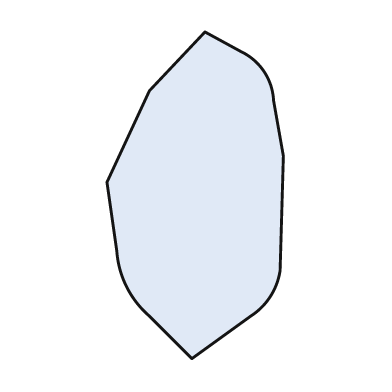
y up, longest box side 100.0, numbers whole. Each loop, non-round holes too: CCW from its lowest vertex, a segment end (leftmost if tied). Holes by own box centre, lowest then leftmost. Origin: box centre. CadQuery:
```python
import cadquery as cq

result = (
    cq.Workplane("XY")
    .moveTo(-1.0, -50.0)
    .lineTo(17.0, -37.0)
    .threePointArc((23.0, -31.0), (26.0, -23.0))
    .lineTo(27.0, 12.0)
    .lineTo(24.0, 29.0)
    .threePointArc((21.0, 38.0), (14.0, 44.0))
    .lineTo(3.0, 50.0)
    .lineTo(-14.0, 32.0)
    .lineTo(-27.0, 4.0)
    .lineTo(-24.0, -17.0)
    .threePointArc((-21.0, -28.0), (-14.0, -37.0))
    .close()
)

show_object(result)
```